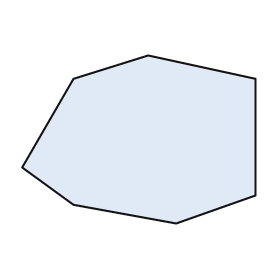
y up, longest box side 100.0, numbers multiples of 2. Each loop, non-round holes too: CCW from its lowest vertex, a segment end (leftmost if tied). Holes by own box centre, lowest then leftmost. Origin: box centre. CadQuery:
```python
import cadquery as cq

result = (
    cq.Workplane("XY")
    .moveTo(16.0, -36.0)
    .lineTo(50.0, -24.0)
    .lineTo(50.0, 26.0)
    .lineTo(4.0, 36.0)
    .lineTo(-28.0, 26.0)
    .lineTo(-50.0, -12.0)
    .lineTo(-28.0, -28.0)
    .close()
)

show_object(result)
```